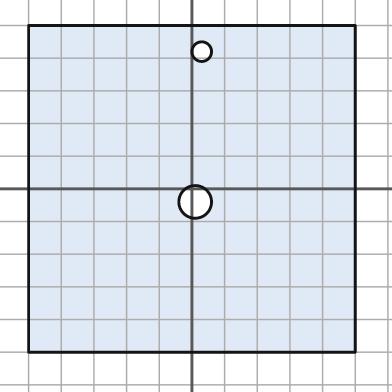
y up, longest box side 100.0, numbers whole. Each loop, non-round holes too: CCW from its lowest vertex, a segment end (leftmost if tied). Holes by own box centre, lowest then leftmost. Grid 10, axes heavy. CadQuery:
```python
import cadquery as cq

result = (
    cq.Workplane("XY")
    .moveTo(-50.0, -50.0)
    .lineTo(50.0, -50.0)
    .lineTo(50.0, 50.0)
    .lineTo(-50.0, 50.0)
    .close()
    .moveTo(1.0, -4.0)
    .circle(5.0)
    .moveTo(3.0, 42.0)
    .circle(3.0)
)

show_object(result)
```